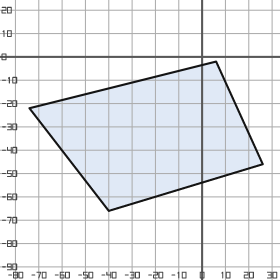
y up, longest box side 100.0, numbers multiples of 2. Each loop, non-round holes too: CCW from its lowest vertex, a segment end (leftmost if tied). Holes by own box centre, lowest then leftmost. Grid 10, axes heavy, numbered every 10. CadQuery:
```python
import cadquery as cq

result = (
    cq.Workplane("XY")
    .moveTo(-40.0, -66.0)
    .lineTo(26.0, -46.0)
    .lineTo(6.0, -2.0)
    .lineTo(-74.0, -22.0)
    .close()
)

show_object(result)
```